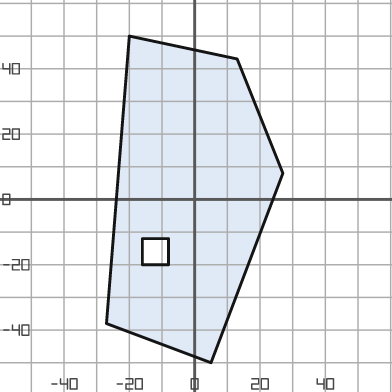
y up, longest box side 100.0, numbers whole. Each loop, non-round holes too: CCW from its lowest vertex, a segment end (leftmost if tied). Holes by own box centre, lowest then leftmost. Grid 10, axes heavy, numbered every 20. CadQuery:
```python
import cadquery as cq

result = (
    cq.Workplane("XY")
    .moveTo(5.0, -50.0)
    .lineTo(27.0, 8.0)
    .lineTo(13.0, 43.0)
    .lineTo(-20.0, 50.0)
    .lineTo(-27.0, -38.0)
    .close()
    .moveTo(-16.0, -20.0)
    .lineTo(-8.0, -20.0)
    .lineTo(-8.0, -12.0)
    .lineTo(-16.0, -12.0)
    .close()
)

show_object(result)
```